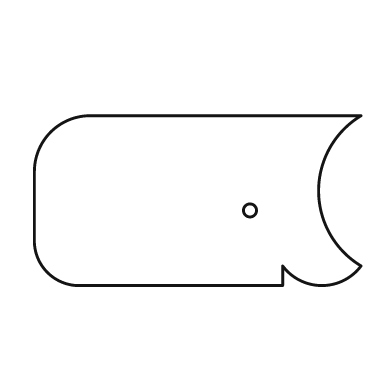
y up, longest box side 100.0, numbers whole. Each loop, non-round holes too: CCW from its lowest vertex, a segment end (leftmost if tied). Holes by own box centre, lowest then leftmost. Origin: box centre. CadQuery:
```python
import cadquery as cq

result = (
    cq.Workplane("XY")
    .moveTo(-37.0, -26.0)
    .lineTo(26.0, -26.0)
    .lineTo(26.0, -20.0)
    .threePointArc((38.0, -26.0), (50.0, -20.0))
    .threePointArc((37.0, 3.0), (50.0, 26.0))
    .lineTo(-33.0, 26.0)
    .threePointArc((-45.0, 21.0), (-50.0, 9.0))
    .lineTo(-50.0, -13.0)
    .threePointArc((-46.0, -22.0), (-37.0, -26.0))
    .close()
    .moveTo(16.0, -3.0)
    .circle(2.0)
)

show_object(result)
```